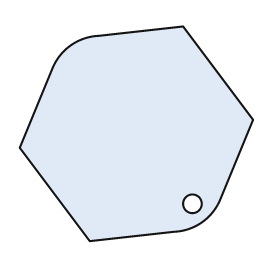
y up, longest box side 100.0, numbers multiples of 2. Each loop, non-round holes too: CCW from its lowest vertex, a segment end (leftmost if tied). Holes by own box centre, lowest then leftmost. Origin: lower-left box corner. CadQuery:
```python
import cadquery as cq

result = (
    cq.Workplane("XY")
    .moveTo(30.0, 0.0)
    .lineTo(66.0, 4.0)
    .threePointArc((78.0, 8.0), (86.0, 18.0))
    .lineTo(100.0, 52.0)
    .lineTo(70.0, 92.0)
    .lineTo(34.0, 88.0)
    .threePointArc((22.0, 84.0), (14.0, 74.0))
    .lineTo(0.0, 40.0)
    .close()
    .moveTo(74.0, 16.0)
    .circle(4.0)
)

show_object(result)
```